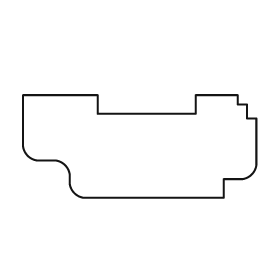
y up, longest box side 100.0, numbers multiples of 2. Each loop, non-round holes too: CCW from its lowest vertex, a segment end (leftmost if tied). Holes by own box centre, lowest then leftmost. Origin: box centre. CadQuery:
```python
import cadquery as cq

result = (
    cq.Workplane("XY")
    .moveTo(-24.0, -22.0)
    .lineTo(36.0, -22.0)
    .lineTo(36.0, -14.0)
    .lineTo(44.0, -14.0)
    .threePointArc((48.0, -12.0), (50.0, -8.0))
    .lineTo(50.0, 12.0)
    .lineTo(46.0, 12.0)
    .lineTo(46.0, 18.0)
    .lineTo(42.0, 18.0)
    .lineTo(42.0, 22.0)
    .lineTo(24.0, 22.0)
    .lineTo(24.0, 14.0)
    .lineTo(-18.0, 14.0)
    .lineTo(-18.0, 22.0)
    .lineTo(-50.0, 22.0)
    .lineTo(-50.0, 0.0)
    .threePointArc((-48.0, -4.0), (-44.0, -6.0))
    .lineTo(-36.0, -6.0)
    .threePointArc((-32.0, -8.0), (-30.0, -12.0))
    .lineTo(-30.0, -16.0)
    .threePointArc((-28.0, -20.0), (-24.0, -22.0))
    .close()
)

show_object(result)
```